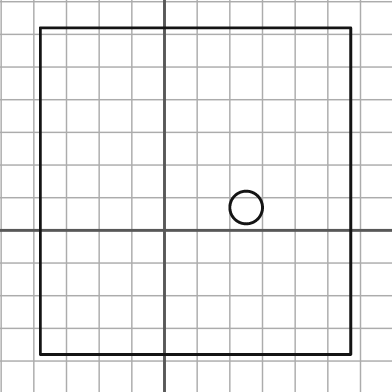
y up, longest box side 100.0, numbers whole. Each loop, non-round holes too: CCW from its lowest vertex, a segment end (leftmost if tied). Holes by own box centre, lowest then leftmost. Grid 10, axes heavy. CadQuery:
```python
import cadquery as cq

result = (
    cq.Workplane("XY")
    .moveTo(-38.0, -38.0)
    .lineTo(57.0, -38.0)
    .lineTo(57.0, 62.0)
    .lineTo(-38.0, 62.0)
    .close()
    .moveTo(25.0, 7.0)
    .circle(5.0)
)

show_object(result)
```